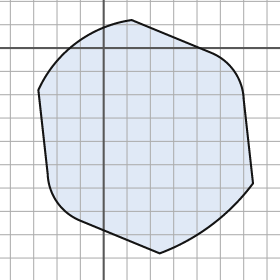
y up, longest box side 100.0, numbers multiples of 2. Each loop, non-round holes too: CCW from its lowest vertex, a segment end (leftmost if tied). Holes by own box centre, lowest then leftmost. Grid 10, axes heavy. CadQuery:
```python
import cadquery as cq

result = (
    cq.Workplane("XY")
    .moveTo(24.0, -88.0)
    .threePointArc((46.0, -76.0), (64.0, -58.0))
    .lineTo(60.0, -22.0)
    .threePointArc((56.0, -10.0), (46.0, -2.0))
    .lineTo(12.0, 12.0)
    .threePointArc((-12.0, 2.0), (-28.0, -18.0))
    .lineTo(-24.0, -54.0)
    .threePointArc((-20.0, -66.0), (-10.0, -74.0))
    .close()
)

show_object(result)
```